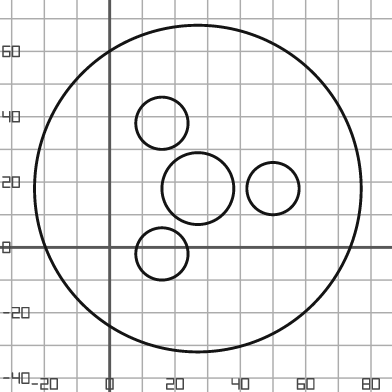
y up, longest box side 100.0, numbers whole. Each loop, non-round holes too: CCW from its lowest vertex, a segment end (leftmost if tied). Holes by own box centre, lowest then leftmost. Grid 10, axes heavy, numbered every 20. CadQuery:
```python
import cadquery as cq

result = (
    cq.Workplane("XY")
    .moveTo(27.0, 18.0)
    .circle(50.0)
    .moveTo(16.0, -2.0)
    .circle(8.0)
    .moveTo(27.0, 18.0)
    .circle(11.0)
    .moveTo(50.0, 18.0)
    .circle(8.0)
    .moveTo(16.0, 38.0)
    .circle(8.0)
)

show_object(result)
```